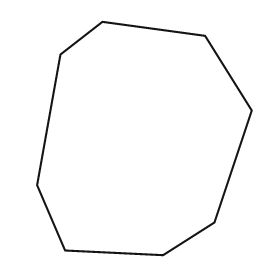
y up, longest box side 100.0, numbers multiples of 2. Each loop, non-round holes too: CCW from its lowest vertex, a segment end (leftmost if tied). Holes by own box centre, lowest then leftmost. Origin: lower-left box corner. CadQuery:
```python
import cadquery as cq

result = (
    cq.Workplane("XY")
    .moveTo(54.0, 0.0)
    .lineTo(76.0, 14.0)
    .lineTo(92.0, 62.0)
    .lineTo(72.0, 94.0)
    .lineTo(28.0, 100.0)
    .lineTo(10.0, 86.0)
    .lineTo(0.0, 30.0)
    .lineTo(12.0, 2.0)
    .close()
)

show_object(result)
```